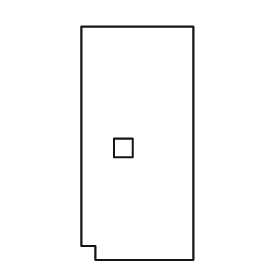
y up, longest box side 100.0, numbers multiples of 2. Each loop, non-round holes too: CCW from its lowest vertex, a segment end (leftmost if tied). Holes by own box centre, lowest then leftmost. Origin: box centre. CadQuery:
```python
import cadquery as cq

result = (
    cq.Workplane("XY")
    .moveTo(-18.0, -50.0)
    .lineTo(24.0, -50.0)
    .lineTo(24.0, 50.0)
    .lineTo(-24.0, 50.0)
    .lineTo(-24.0, -44.0)
    .lineTo(-18.0, -44.0)
    .close()
    .moveTo(-10.0, -6.0)
    .lineTo(-2.0, -6.0)
    .lineTo(-2.0, 2.0)
    .lineTo(-10.0, 2.0)
    .close()
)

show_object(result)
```